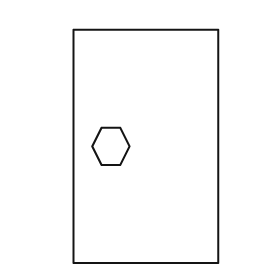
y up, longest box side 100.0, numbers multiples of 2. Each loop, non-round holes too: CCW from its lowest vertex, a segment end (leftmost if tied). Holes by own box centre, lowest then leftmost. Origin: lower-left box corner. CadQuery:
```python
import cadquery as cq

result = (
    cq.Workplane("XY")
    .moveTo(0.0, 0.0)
    .lineTo(62.0, 0.0)
    .lineTo(62.0, 100.0)
    .lineTo(0.0, 100.0)
    .close()
    .moveTo(12.0, 42.0)
    .lineTo(20.0, 42.0)
    .lineTo(24.0, 50.0)
    .lineTo(20.0, 58.0)
    .lineTo(12.0, 58.0)
    .lineTo(8.0, 50.0)
    .close()
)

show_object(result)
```